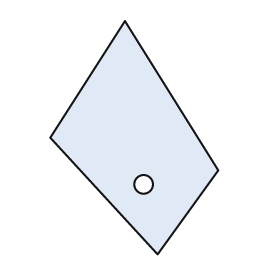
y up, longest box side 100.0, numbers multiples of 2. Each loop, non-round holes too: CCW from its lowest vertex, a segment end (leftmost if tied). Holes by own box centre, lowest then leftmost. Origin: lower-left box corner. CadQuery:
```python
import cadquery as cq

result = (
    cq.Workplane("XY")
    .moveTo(46.0, 0.0)
    .lineTo(72.0, 36.0)
    .lineTo(32.0, 100.0)
    .lineTo(0.0, 50.0)
    .close()
    .moveTo(40.0, 30.0)
    .circle(4.0)
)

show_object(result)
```